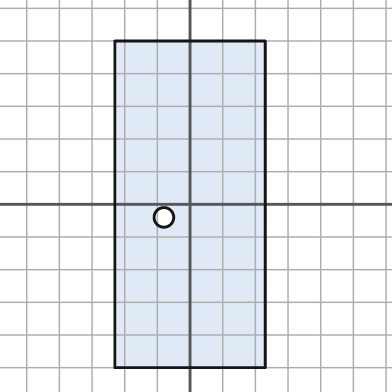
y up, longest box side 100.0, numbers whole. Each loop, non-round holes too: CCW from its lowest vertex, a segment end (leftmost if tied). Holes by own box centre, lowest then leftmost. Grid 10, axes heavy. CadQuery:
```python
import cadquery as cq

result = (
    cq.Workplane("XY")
    .moveTo(-23.0, -50.0)
    .lineTo(23.0, -50.0)
    .lineTo(23.0, 50.0)
    .lineTo(-23.0, 50.0)
    .close()
    .moveTo(-8.0, -4.0)
    .circle(3.0)
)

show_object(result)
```